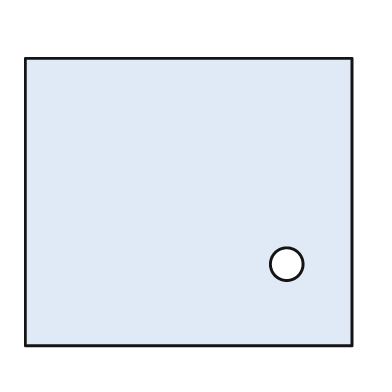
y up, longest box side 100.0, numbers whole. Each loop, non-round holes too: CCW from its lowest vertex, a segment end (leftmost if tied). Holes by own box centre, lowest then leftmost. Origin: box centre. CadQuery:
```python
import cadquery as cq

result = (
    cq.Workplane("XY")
    .moveTo(-50.0, -44.0)
    .lineTo(50.0, -44.0)
    .lineTo(50.0, 44.0)
    .lineTo(-50.0, 44.0)
    .close()
    .moveTo(30.0, -19.0)
    .circle(5.0)
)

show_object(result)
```